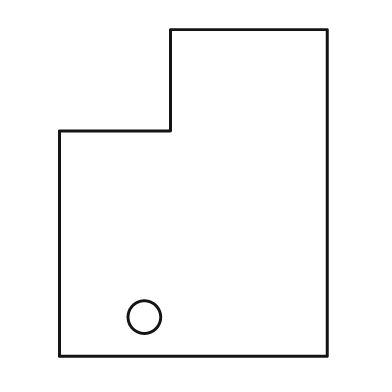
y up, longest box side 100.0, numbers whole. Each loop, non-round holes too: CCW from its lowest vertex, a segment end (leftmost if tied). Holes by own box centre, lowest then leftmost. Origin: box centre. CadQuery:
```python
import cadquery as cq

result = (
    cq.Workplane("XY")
    .moveTo(-41.0, -50.0)
    .lineTo(41.0, -50.0)
    .lineTo(41.0, 50.0)
    .lineTo(-7.0, 50.0)
    .lineTo(-7.0, 19.0)
    .lineTo(-41.0, 19.0)
    .close()
    .moveTo(-15.0, -38.0)
    .circle(5.0)
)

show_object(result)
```